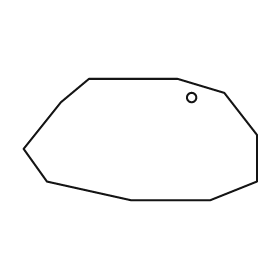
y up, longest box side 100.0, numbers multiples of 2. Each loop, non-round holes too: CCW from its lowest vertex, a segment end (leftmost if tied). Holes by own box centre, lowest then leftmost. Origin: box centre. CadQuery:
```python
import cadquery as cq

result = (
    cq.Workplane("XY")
    .moveTo(-4.0, -26.0)
    .lineTo(30.0, -26.0)
    .lineTo(50.0, -18.0)
    .lineTo(50.0, 2.0)
    .lineTo(36.0, 20.0)
    .lineTo(16.0, 26.0)
    .lineTo(-22.0, 26.0)
    .lineTo(-34.0, 16.0)
    .lineTo(-50.0, -4.0)
    .lineTo(-40.0, -18.0)
    .close()
    .moveTo(22.0, 18.0)
    .circle(2.0)
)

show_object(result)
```